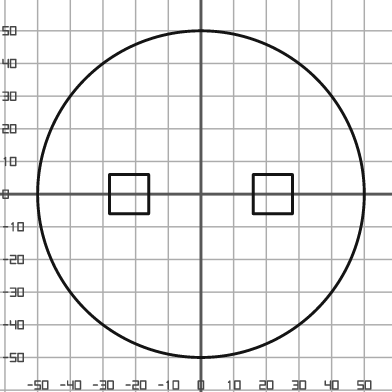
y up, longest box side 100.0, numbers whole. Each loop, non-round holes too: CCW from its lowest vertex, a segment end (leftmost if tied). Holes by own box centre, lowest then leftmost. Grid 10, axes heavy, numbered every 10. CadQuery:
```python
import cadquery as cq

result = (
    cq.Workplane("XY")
    .moveTo(0.0, 0.0)
    .circle(50.0)
    .moveTo(-28.0, -6.0)
    .lineTo(-16.0, -6.0)
    .lineTo(-16.0, 6.0)
    .lineTo(-28.0, 6.0)
    .close()
    .moveTo(16.0, -6.0)
    .lineTo(28.0, -6.0)
    .lineTo(28.0, 6.0)
    .lineTo(16.0, 6.0)
    .close()
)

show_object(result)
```